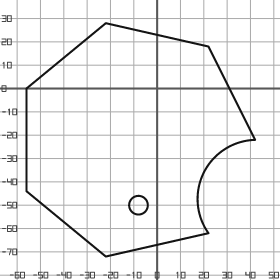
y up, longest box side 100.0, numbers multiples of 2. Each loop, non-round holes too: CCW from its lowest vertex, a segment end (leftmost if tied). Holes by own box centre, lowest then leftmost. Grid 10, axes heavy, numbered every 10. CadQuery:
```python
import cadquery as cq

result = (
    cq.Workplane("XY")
    .moveTo(-22.0, -72.0)
    .lineTo(22.0, -62.0)
    .threePointArc((20.0, -36.0), (42.0, -22.0))
    .lineTo(22.0, 18.0)
    .lineTo(-22.0, 28.0)
    .lineTo(-56.0, 0.0)
    .lineTo(-56.0, -44.0)
    .close()
    .moveTo(-8.0, -50.0)
    .circle(4.0)
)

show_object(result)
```